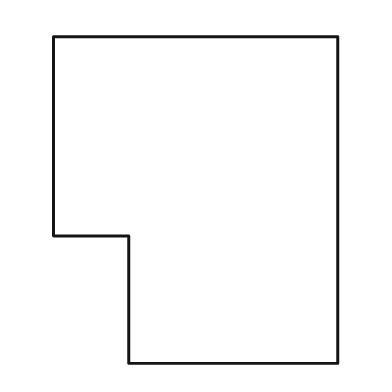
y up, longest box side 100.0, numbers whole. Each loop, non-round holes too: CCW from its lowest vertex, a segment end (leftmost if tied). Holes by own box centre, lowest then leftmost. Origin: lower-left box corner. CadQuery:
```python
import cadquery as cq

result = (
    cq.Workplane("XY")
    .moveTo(23.0, 0.0)
    .lineTo(87.0, 0.0)
    .lineTo(87.0, 100.0)
    .lineTo(0.0, 100.0)
    .lineTo(0.0, 39.0)
    .lineTo(23.0, 39.0)
    .close()
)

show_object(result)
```